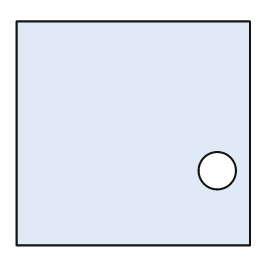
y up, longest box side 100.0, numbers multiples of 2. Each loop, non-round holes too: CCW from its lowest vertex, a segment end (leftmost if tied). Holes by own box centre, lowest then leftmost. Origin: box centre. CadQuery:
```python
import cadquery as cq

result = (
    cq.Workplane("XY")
    .moveTo(-50.0, -48.0)
    .lineTo(50.0, -48.0)
    .lineTo(50.0, 48.0)
    .lineTo(-50.0, 48.0)
    .close()
    .moveTo(36.0, -16.0)
    .circle(8.0)
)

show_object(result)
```